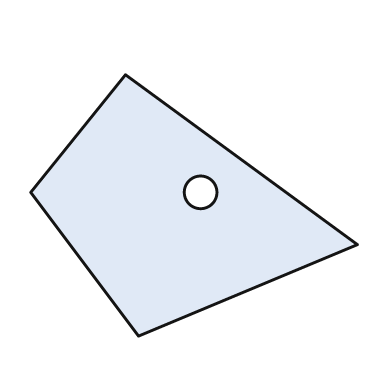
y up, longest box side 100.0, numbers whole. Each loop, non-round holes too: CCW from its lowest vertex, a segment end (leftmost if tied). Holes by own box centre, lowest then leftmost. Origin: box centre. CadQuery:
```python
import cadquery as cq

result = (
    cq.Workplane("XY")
    .moveTo(-17.0, -40.0)
    .lineTo(50.0, -12.0)
    .lineTo(-21.0, 40.0)
    .lineTo(-50.0, 4.0)
    .close()
    .moveTo(2.0, 4.0)
    .circle(5.0)
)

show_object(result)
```